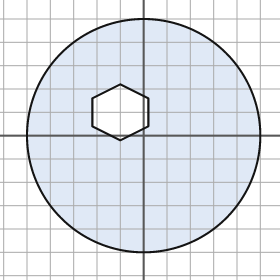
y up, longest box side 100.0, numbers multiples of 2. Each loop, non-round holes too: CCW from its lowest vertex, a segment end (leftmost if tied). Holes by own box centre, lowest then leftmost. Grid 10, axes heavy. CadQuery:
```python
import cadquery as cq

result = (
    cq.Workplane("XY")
    .moveTo(0.0, 0.0)
    .circle(50.0)
    .moveTo(-10.0, -2.0)
    .lineTo(2.0, 4.0)
    .lineTo(2.0, 16.0)
    .lineTo(-10.0, 22.0)
    .lineTo(-22.0, 16.0)
    .lineTo(-22.0, 4.0)
    .close()
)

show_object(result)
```